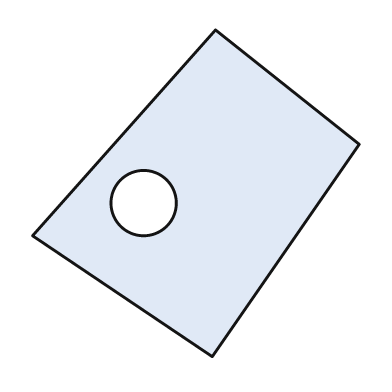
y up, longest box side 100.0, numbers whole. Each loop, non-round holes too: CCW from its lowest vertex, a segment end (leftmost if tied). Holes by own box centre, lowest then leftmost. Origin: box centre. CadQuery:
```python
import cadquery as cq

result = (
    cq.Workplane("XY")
    .moveTo(5.0, -50.0)
    .lineTo(50.0, 15.0)
    .lineTo(6.0, 50.0)
    .lineTo(-50.0, -13.0)
    .close()
    .moveTo(-16.0, -3.0)
    .circle(10.0)
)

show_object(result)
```